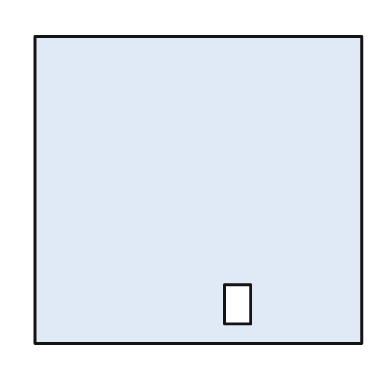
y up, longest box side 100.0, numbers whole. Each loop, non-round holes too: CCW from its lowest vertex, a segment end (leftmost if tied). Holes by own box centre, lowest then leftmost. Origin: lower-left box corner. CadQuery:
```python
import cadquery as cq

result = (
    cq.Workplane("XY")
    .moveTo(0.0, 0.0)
    .lineTo(100.0, 0.0)
    .lineTo(100.0, 94.0)
    .lineTo(0.0, 94.0)
    .close()
    .moveTo(58.0, 6.0)
    .lineTo(66.0, 6.0)
    .lineTo(66.0, 18.0)
    .lineTo(58.0, 18.0)
    .close()
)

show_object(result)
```